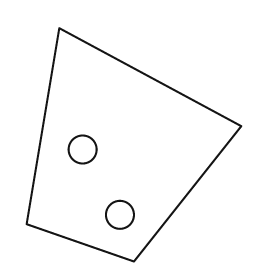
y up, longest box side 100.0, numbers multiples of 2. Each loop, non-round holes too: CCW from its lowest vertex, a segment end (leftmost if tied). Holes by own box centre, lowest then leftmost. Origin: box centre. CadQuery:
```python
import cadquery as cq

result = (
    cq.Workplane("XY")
    .moveTo(0.0, -50.0)
    .lineTo(46.0, 8.0)
    .lineTo(-32.0, 50.0)
    .lineTo(-46.0, -34.0)
    .close()
    .moveTo(-6.0, -30.0)
    .circle(6.0)
    .moveTo(-22.0, -2.0)
    .circle(6.0)
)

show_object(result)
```